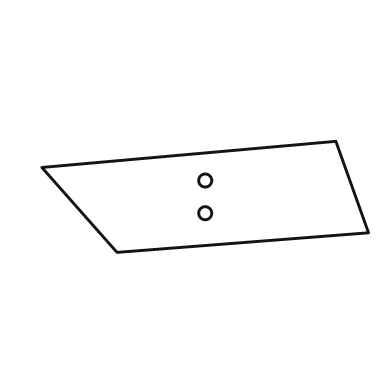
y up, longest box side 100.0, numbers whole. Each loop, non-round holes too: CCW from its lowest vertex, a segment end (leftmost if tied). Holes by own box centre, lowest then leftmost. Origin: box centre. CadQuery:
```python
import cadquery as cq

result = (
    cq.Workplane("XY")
    .moveTo(-27.0, -17.0)
    .lineTo(50.0, -11.0)
    .lineTo(40.0, 17.0)
    .lineTo(-50.0, 9.0)
    .close()
    .moveTo(0.0, -5.0)
    .circle(2.0)
    .moveTo(0.0, 5.0)
    .circle(2.0)
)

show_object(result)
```